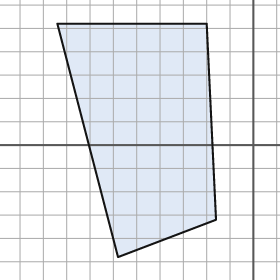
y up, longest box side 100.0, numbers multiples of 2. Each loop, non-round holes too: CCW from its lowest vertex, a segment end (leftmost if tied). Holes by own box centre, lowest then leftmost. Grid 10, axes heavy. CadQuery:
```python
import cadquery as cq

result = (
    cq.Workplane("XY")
    .moveTo(-58.0, -48.0)
    .lineTo(-16.0, -32.0)
    .lineTo(-20.0, 52.0)
    .lineTo(-84.0, 52.0)
    .close()
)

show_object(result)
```